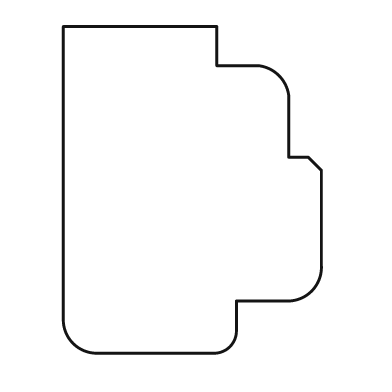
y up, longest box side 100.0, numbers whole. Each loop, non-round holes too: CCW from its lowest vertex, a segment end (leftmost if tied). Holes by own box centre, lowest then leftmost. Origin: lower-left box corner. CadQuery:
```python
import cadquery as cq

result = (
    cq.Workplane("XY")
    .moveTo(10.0, 0.0)
    .lineTo(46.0, 0.0)
    .threePointArc((51.0, 2.0), (53.0, 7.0))
    .lineTo(53.0, 16.0)
    .lineTo(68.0, 16.0)
    .threePointArc((76.0, 19.0), (79.0, 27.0))
    .lineTo(79.0, 56.0)
    .lineTo(75.0, 60.0)
    .lineTo(69.0, 60.0)
    .lineTo(69.0, 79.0)
    .threePointArc((66.0, 85.0), (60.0, 88.0))
    .lineTo(47.0, 88.0)
    .lineTo(47.0, 100.0)
    .lineTo(0.0, 100.0)
    .lineTo(0.0, 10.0)
    .threePointArc((3.0, 3.0), (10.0, 0.0))
    .close()
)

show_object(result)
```